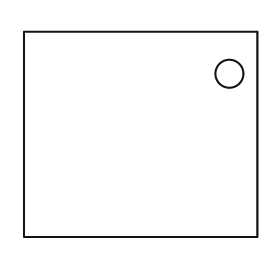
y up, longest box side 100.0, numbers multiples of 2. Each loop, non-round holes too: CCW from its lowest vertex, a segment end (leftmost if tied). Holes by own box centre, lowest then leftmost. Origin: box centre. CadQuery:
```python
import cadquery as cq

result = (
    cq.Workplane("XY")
    .moveTo(-50.0, -44.0)
    .lineTo(50.0, -44.0)
    .lineTo(50.0, 44.0)
    .lineTo(-50.0, 44.0)
    .close()
    .moveTo(38.0, 26.0)
    .circle(6.0)
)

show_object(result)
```